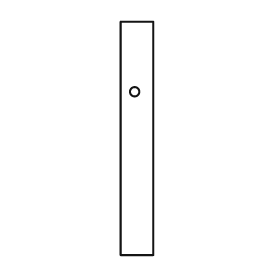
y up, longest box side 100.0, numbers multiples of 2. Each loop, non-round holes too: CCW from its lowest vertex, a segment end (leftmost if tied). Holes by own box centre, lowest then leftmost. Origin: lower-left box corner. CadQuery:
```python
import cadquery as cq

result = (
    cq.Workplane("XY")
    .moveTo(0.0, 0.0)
    .lineTo(14.0, 0.0)
    .lineTo(14.0, 100.0)
    .lineTo(0.0, 100.0)
    .close()
    .moveTo(6.0, 70.0)
    .circle(2.0)
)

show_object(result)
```